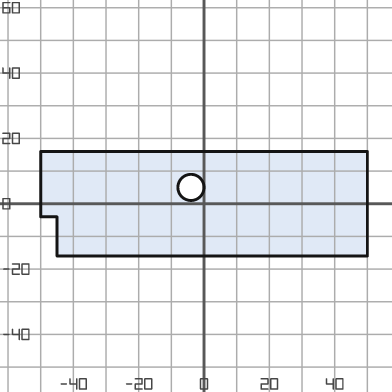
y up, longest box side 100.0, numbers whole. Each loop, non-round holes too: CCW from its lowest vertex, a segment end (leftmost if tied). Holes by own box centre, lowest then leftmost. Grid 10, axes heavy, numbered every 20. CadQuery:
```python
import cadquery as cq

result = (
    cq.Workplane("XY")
    .moveTo(-45.0, -16.0)
    .lineTo(50.0, -16.0)
    .lineTo(50.0, 16.0)
    .lineTo(-50.0, 16.0)
    .lineTo(-50.0, -4.0)
    .lineTo(-45.0, -4.0)
    .close()
    .moveTo(-4.0, 5.0)
    .circle(4.0)
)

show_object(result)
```